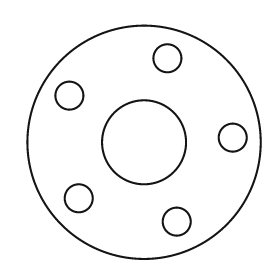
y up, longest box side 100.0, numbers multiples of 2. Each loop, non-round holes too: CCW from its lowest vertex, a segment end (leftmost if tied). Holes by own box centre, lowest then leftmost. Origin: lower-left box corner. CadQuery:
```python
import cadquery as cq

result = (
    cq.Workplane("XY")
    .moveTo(50.0, 50.0)
    .circle(50.0)
    .moveTo(64.0, 16.0)
    .circle(6.0)
    .moveTo(22.0, 26.0)
    .circle(6.0)
    .moveTo(50.0, 50.0)
    .circle(18.0)
    .moveTo(88.0, 52.0)
    .circle(6.0)
    .moveTo(18.0, 70.0)
    .circle(6.0)
    .moveTo(60.0, 86.0)
    .circle(6.0)
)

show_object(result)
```